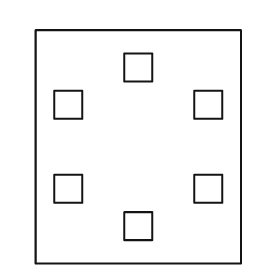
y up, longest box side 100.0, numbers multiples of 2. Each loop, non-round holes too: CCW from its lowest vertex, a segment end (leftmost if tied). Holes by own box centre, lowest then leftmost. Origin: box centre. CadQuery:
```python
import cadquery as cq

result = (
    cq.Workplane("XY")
    .moveTo(-44.0, -50.0)
    .lineTo(44.0, -50.0)
    .lineTo(44.0, 50.0)
    .lineTo(-44.0, 50.0)
    .close()
    .moveTo(-6.0, -40.0)
    .lineTo(6.0, -40.0)
    .lineTo(6.0, -28.0)
    .lineTo(-6.0, -28.0)
    .close()
    .moveTo(-36.0, -24.0)
    .lineTo(-24.0, -24.0)
    .lineTo(-24.0, -12.0)
    .lineTo(-36.0, -12.0)
    .close()
    .moveTo(24.0, -24.0)
    .lineTo(36.0, -24.0)
    .lineTo(36.0, -12.0)
    .lineTo(24.0, -12.0)
    .close()
    .moveTo(-36.0, 12.0)
    .lineTo(-24.0, 12.0)
    .lineTo(-24.0, 24.0)
    .lineTo(-36.0, 24.0)
    .close()
    .moveTo(24.0, 12.0)
    .lineTo(36.0, 12.0)
    .lineTo(36.0, 24.0)
    .lineTo(24.0, 24.0)
    .close()
    .moveTo(-6.0, 28.0)
    .lineTo(6.0, 28.0)
    .lineTo(6.0, 40.0)
    .lineTo(-6.0, 40.0)
    .close()
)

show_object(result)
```